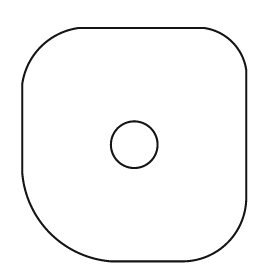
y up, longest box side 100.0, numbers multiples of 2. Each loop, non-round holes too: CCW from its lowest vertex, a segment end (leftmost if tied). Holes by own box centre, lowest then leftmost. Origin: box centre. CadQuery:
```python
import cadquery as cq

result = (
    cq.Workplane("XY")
    .moveTo(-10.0, -50.0)
    .lineTo(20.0, -50.0)
    .threePointArc((40.0, -42.0), (48.0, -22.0))
    .lineTo(48.0, 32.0)
    .threePointArc((42.0, 44.0), (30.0, 50.0))
    .lineTo(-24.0, 50.0)
    .threePointArc((-40.0, 42.0), (-48.0, 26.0))
    .lineTo(-48.0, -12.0)
    .threePointArc((-36.0, -38.0), (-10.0, -50.0))
    .close()
    .moveTo(0.0, 0.0)
    .circle(10.0)
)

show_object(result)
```